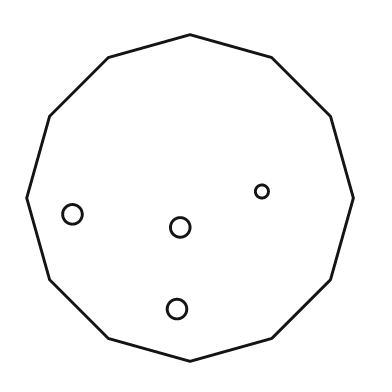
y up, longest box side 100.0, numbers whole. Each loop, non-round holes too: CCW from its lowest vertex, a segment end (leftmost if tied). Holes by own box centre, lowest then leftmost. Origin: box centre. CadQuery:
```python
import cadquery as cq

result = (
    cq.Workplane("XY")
    .moveTo(0.0, -50.0)
    .lineTo(25.0, -43.0)
    .lineTo(43.0, -25.0)
    .lineTo(50.0, 0.0)
    .lineTo(43.0, 25.0)
    .lineTo(25.0, 43.0)
    .lineTo(0.0, 50.0)
    .lineTo(-25.0, 43.0)
    .lineTo(-43.0, 25.0)
    .lineTo(-50.0, 0.0)
    .lineTo(-43.0, -25.0)
    .lineTo(-25.0, -43.0)
    .close()
    .moveTo(-4.0, -34.0)
    .circle(3.0)
    .moveTo(-3.0, -9.0)
    .circle(3.0)
    .moveTo(-36.0, -5.0)
    .circle(3.0)
    .moveTo(22.0, 2.0)
    .circle(2.0)
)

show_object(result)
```